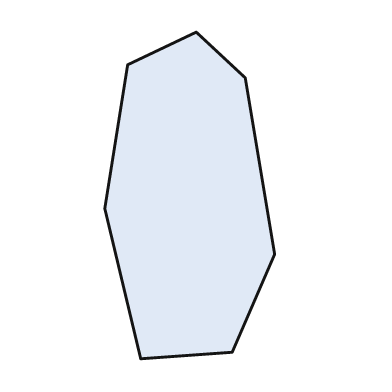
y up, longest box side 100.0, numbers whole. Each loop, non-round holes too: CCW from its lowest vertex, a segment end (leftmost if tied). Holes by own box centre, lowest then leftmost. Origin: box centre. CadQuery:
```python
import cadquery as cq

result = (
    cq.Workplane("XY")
    .moveTo(-15.0, -50.0)
    .lineTo(13.0, -48.0)
    .lineTo(26.0, -18.0)
    .lineTo(17.0, 36.0)
    .lineTo(2.0, 50.0)
    .lineTo(-19.0, 40.0)
    .lineTo(-26.0, -4.0)
    .close()
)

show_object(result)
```